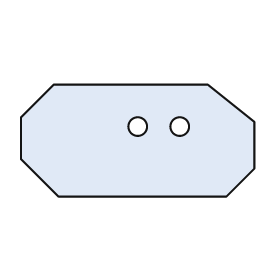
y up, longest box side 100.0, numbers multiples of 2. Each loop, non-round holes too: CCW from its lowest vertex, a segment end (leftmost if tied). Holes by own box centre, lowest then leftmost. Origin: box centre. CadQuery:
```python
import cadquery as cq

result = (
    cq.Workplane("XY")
    .moveTo(-34.0, -24.0)
    .lineTo(38.0, -24.0)
    .lineTo(50.0, -12.0)
    .lineTo(50.0, 8.0)
    .lineTo(30.0, 24.0)
    .lineTo(-36.0, 24.0)
    .lineTo(-50.0, 10.0)
    .lineTo(-50.0, -8.0)
    .close()
    .moveTo(0.0, 6.0)
    .circle(4.0)
    .moveTo(18.0, 6.0)
    .circle(4.0)
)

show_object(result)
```